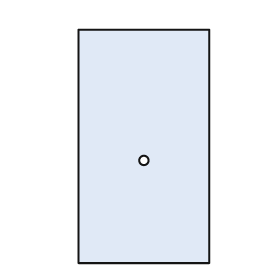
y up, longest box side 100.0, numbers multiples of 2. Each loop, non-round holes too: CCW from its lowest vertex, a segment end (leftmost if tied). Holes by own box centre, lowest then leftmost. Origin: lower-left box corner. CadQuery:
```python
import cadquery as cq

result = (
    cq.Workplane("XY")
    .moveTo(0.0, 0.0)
    .lineTo(56.0, 0.0)
    .lineTo(56.0, 100.0)
    .lineTo(0.0, 100.0)
    .close()
    .moveTo(28.0, 44.0)
    .circle(2.0)
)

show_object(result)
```